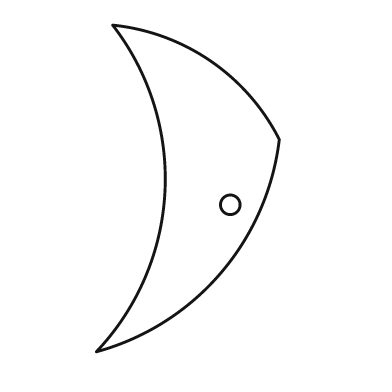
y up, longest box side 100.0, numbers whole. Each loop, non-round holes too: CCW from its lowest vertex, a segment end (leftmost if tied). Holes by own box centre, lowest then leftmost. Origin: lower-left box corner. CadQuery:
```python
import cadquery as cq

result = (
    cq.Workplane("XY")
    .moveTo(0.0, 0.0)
    .threePointArc((38.0, 24.0), (56.0, 65.0))
    .threePointArc((35.0, 89.0), (5.0, 100.0))
    .threePointArc((21.0, 49.0), (0.0, 0.0))
    .close()
    .moveTo(41.0, 45.0)
    .circle(3.0)
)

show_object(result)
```